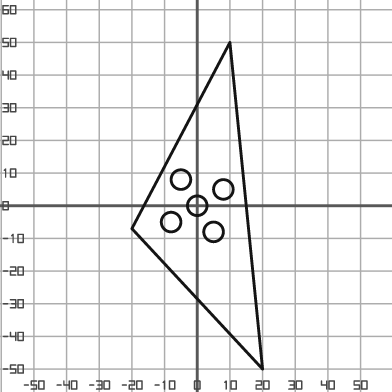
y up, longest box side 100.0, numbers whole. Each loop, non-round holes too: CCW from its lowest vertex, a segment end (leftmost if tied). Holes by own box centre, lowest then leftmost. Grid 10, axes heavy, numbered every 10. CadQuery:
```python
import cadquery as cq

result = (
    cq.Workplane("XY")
    .moveTo(20.0, -50.0)
    .lineTo(10.0, 50.0)
    .lineTo(-20.0, -7.0)
    .close()
    .moveTo(5.0, -8.0)
    .circle(3.0)
    .moveTo(-8.0, -5.0)
    .circle(3.0)
    .moveTo(0.0, 0.0)
    .circle(3.0)
    .moveTo(8.0, 5.0)
    .circle(3.0)
    .moveTo(-5.0, 8.0)
    .circle(3.0)
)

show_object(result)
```